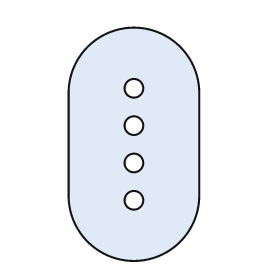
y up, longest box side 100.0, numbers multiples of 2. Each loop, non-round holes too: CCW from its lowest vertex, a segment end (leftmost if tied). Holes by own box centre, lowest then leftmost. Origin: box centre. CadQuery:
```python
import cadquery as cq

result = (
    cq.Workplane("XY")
    .moveTo(-28.0, -22.0)
    .threePointArc((0.0, -50.0), (28.0, -22.0))
    .lineTo(28.0, 22.0)
    .threePointArc((0.0, 50.0), (-28.0, 22.0))
    .close()
    .moveTo(0.0, -24.0)
    .circle(4.0)
    .moveTo(0.0, -8.0)
    .circle(4.0)
    .moveTo(0.0, 8.0)
    .circle(4.0)
    .moveTo(0.0, 24.0)
    .circle(4.0)
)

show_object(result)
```